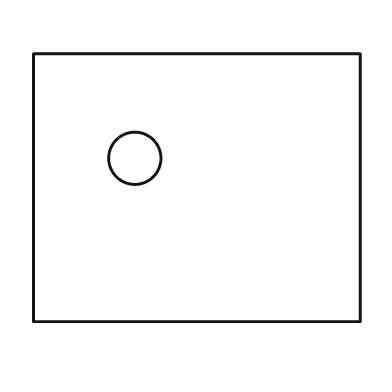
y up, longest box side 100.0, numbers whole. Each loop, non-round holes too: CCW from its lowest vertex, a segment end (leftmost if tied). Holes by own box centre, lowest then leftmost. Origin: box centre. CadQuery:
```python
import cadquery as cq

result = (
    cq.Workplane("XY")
    .moveTo(-50.0, -41.0)
    .lineTo(50.0, -41.0)
    .lineTo(50.0, 41.0)
    .lineTo(-50.0, 41.0)
    .close()
    .moveTo(-19.0, 9.0)
    .circle(8.0)
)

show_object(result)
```